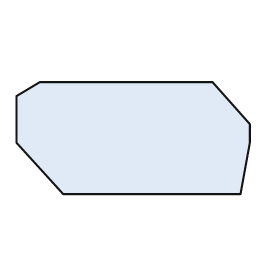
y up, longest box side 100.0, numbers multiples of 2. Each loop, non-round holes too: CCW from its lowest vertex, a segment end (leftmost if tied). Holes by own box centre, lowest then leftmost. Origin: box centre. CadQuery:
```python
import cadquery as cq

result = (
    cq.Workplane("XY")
    .moveTo(-30.0, -24.0)
    .lineTo(46.0, -24.0)
    .lineTo(50.0, -2.0)
    .lineTo(50.0, 6.0)
    .lineTo(34.0, 24.0)
    .lineTo(-40.0, 24.0)
    .lineTo(-50.0, 18.0)
    .lineTo(-50.0, -2.0)
    .close()
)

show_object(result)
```